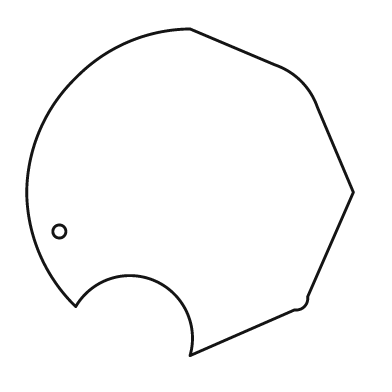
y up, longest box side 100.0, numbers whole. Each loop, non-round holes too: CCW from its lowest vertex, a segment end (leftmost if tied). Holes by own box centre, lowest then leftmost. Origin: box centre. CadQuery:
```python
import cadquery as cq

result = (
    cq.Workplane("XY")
    .moveTo(0.0, -50.0)
    .lineTo(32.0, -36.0)
    .threePointArc((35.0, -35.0), (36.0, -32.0))
    .lineTo(50.0, 0.0)
    .lineTo(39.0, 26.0)
    .threePointArc((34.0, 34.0), (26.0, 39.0))
    .lineTo(0.0, 50.0)
    .threePointArc((-19.0, 46.0), (-35.0, 35.0))
    .threePointArc((-46.0, 19.0), (-50.0, 0.0))
    .threePointArc((-46.0, -19.0), (-35.0, -35.0))
    .threePointArc((-11.0, -27.0), (0.0, -50.0))
    .close()
    .moveTo(-40.0, -12.0)
    .circle(2.0)
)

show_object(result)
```